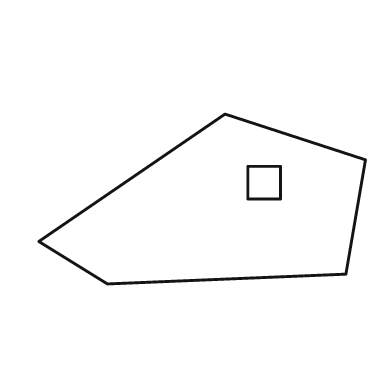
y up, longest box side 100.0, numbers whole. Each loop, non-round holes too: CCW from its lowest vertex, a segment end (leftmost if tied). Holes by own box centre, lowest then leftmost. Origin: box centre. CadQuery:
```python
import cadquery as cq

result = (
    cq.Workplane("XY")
    .moveTo(-29.0, -26.0)
    .lineTo(44.0, -23.0)
    .lineTo(50.0, 12.0)
    .lineTo(7.0, 26.0)
    .lineTo(-50.0, -13.0)
    .close()
    .moveTo(14.0, 0.0)
    .lineTo(24.0, 0.0)
    .lineTo(24.0, 10.0)
    .lineTo(14.0, 10.0)
    .close()
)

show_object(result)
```